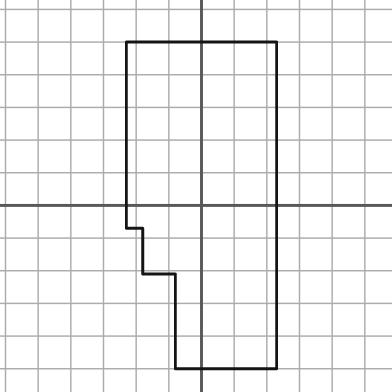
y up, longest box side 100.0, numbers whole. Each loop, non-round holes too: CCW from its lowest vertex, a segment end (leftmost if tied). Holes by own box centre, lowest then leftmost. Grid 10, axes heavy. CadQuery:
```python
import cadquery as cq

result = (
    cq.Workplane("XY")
    .moveTo(-8.0, -50.0)
    .lineTo(23.0, -50.0)
    .lineTo(23.0, 50.0)
    .lineTo(-23.0, 50.0)
    .lineTo(-23.0, -7.0)
    .lineTo(-18.0, -7.0)
    .lineTo(-18.0, -21.0)
    .lineTo(-8.0, -21.0)
    .close()
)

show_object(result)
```